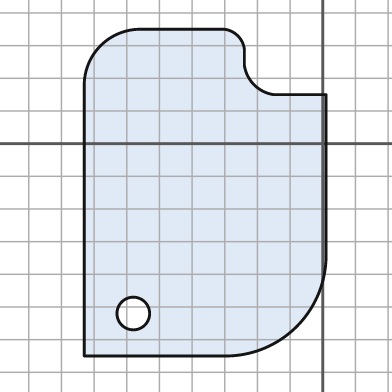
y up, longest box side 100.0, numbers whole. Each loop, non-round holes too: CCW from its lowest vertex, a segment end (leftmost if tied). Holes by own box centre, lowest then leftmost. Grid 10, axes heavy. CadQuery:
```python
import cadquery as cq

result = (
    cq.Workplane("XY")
    .moveTo(-73.0, -65.0)
    .lineTo(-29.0, -65.0)
    .threePointArc((-8.0, -56.0), (1.0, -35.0))
    .lineTo(1.0, 15.0)
    .lineTo(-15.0, 15.0)
    .threePointArc((-21.0, 18.0), (-24.0, 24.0))
    .lineTo(-24.0, 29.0)
    .threePointArc((-26.0, 33.0), (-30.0, 35.0))
    .lineTo(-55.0, 35.0)
    .threePointArc((-68.0, 30.0), (-73.0, 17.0))
    .close()
    .moveTo(-58.0, -52.0)
    .circle(5.0)
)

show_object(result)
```